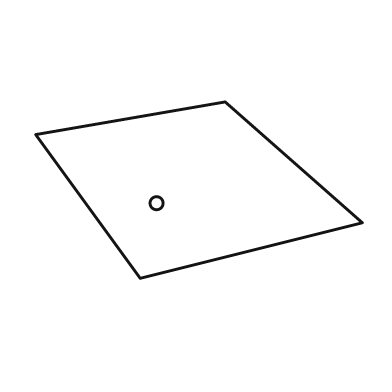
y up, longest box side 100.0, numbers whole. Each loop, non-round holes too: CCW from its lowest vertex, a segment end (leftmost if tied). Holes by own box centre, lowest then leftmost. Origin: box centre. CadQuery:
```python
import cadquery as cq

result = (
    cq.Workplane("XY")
    .moveTo(-18.0, -27.0)
    .lineTo(50.0, -10.0)
    .lineTo(8.0, 27.0)
    .lineTo(-50.0, 17.0)
    .close()
    .moveTo(-13.0, -4.0)
    .circle(2.0)
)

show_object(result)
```